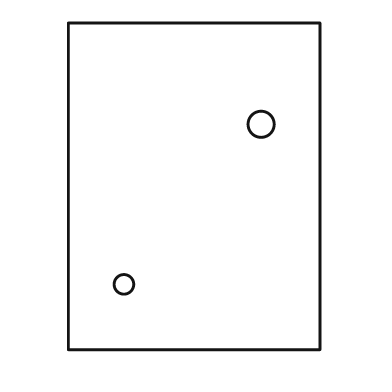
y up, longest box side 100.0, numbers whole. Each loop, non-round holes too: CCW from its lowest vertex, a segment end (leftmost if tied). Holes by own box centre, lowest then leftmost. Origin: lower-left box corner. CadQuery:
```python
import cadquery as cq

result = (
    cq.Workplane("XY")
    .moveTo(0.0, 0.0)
    .lineTo(77.0, 0.0)
    .lineTo(77.0, 100.0)
    .lineTo(0.0, 100.0)
    .close()
    .moveTo(17.0, 20.0)
    .circle(3.0)
    .moveTo(59.0, 69.0)
    .circle(4.0)
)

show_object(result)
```